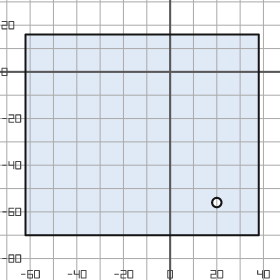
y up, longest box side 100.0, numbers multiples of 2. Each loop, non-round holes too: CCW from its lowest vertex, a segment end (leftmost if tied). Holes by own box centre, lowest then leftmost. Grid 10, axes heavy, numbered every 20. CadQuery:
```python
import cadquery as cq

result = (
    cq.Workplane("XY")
    .moveTo(-62.0, -70.0)
    .lineTo(38.0, -70.0)
    .lineTo(38.0, 16.0)
    .lineTo(-62.0, 16.0)
    .close()
    .moveTo(20.0, -56.0)
    .circle(2.0)
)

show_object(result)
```